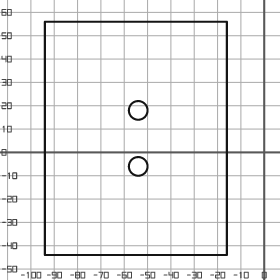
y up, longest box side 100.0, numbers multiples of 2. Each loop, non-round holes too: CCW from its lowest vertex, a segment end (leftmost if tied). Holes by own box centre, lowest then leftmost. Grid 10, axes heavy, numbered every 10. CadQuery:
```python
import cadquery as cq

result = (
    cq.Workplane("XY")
    .moveTo(-94.0, -44.0)
    .lineTo(-16.0, -44.0)
    .lineTo(-16.0, 56.0)
    .lineTo(-94.0, 56.0)
    .close()
    .moveTo(-54.0, -6.0)
    .circle(4.0)
    .moveTo(-54.0, 18.0)
    .circle(4.0)
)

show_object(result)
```